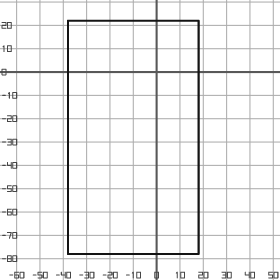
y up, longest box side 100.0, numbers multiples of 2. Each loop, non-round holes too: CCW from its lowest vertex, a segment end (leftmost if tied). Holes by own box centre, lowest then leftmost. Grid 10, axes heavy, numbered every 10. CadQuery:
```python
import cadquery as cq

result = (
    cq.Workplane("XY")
    .moveTo(-38.0, -78.0)
    .lineTo(18.0, -78.0)
    .lineTo(18.0, 22.0)
    .lineTo(-38.0, 22.0)
    .close()
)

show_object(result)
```